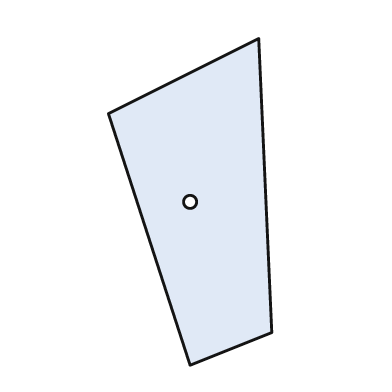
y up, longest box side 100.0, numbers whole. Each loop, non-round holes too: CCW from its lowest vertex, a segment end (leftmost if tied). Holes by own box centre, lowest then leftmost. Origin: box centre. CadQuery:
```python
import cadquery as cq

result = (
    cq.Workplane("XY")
    .moveTo(0.0, -50.0)
    .lineTo(25.0, -40.0)
    .lineTo(21.0, 50.0)
    .lineTo(-25.0, 27.0)
    .close()
    .moveTo(0.0, 0.0)
    .circle(2.0)
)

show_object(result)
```